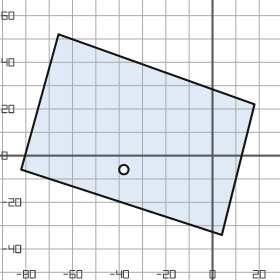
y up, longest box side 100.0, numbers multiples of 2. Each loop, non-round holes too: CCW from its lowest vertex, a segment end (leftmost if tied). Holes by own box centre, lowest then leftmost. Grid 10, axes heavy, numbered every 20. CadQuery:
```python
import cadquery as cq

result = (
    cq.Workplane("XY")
    .moveTo(4.0, -34.0)
    .lineTo(18.0, 22.0)
    .lineTo(-66.0, 52.0)
    .lineTo(-82.0, -6.0)
    .close()
    .moveTo(-38.0, -6.0)
    .circle(2.0)
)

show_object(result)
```